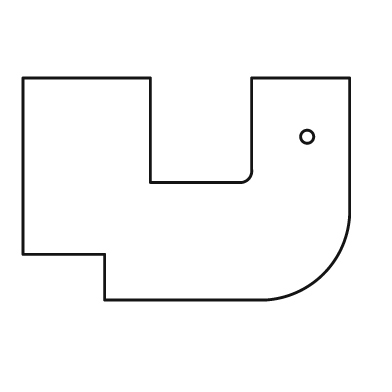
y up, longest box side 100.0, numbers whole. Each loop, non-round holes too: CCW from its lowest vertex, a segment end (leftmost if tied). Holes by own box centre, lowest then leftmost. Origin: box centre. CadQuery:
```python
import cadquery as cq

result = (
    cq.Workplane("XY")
    .moveTo(-25.0, -34.0)
    .lineTo(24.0, -34.0)
    .threePointArc((42.0, -26.0), (50.0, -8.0))
    .lineTo(50.0, 34.0)
    .lineTo(20.0, 34.0)
    .lineTo(20.0, 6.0)
    .threePointArc((19.0, 3.0), (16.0, 2.0))
    .lineTo(-11.0, 2.0)
    .lineTo(-11.0, 34.0)
    .lineTo(-50.0, 34.0)
    .lineTo(-50.0, -20.0)
    .lineTo(-25.0, -20.0)
    .close()
    .moveTo(37.0, 16.0)
    .circle(2.0)
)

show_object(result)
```